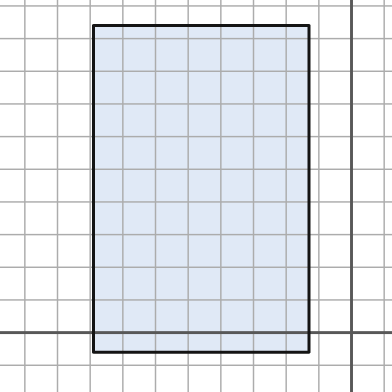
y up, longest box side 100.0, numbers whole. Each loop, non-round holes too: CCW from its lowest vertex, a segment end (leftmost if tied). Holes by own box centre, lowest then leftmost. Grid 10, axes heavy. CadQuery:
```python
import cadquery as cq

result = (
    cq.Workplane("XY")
    .moveTo(-79.0, -6.0)
    .lineTo(-13.0, -6.0)
    .lineTo(-13.0, 94.0)
    .lineTo(-79.0, 94.0)
    .close()
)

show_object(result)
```